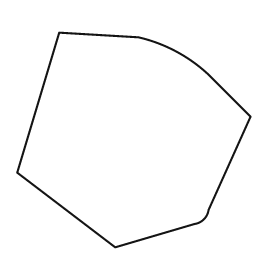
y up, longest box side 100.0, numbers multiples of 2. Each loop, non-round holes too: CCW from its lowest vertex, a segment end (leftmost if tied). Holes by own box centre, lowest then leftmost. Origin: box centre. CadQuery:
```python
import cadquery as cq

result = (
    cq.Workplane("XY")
    .moveTo(-8.0, -46.0)
    .lineTo(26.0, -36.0)
    .threePointArc((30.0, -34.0), (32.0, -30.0))
    .lineTo(50.0, 10.0)
    .lineTo(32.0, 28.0)
    .threePointArc((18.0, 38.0), (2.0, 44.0))
    .lineTo(-32.0, 46.0)
    .lineTo(-50.0, -14.0)
    .close()
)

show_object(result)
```